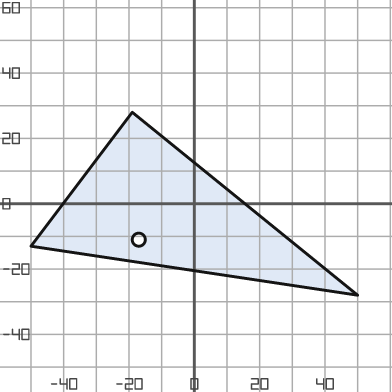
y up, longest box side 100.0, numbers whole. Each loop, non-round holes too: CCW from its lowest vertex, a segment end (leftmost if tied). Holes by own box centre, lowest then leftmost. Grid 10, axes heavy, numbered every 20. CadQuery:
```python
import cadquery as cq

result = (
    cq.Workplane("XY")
    .moveTo(50.0, -28.0)
    .lineTo(-19.0, 28.0)
    .lineTo(-50.0, -13.0)
    .close()
    .moveTo(-17.0, -11.0)
    .circle(2.0)
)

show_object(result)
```